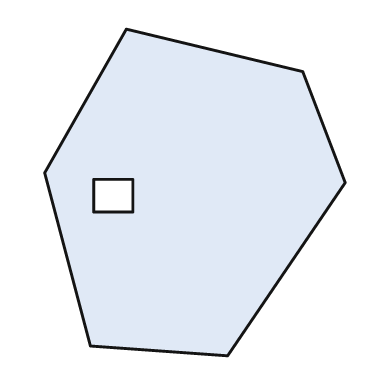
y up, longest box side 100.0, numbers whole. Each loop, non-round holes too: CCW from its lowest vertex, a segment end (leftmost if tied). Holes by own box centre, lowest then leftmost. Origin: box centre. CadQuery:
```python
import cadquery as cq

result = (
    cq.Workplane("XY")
    .moveTo(10.0, -50.0)
    .lineTo(46.0, 3.0)
    .lineTo(33.0, 37.0)
    .lineTo(-21.0, 50.0)
    .lineTo(-46.0, 6.0)
    .lineTo(-32.0, -47.0)
    .close()
    .moveTo(-31.0, -6.0)
    .lineTo(-19.0, -6.0)
    .lineTo(-19.0, 4.0)
    .lineTo(-31.0, 4.0)
    .close()
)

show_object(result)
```